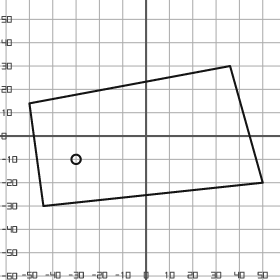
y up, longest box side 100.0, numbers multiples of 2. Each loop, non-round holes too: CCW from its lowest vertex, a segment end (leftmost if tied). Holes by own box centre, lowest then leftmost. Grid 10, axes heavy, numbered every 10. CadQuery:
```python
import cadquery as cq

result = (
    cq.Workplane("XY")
    .moveTo(-44.0, -30.0)
    .lineTo(50.0, -20.0)
    .lineTo(36.0, 30.0)
    .lineTo(-50.0, 14.0)
    .close()
    .moveTo(-30.0, -10.0)
    .circle(2.0)
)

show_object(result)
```